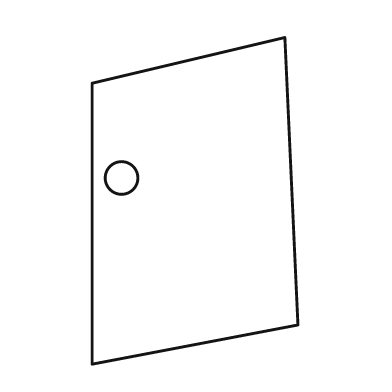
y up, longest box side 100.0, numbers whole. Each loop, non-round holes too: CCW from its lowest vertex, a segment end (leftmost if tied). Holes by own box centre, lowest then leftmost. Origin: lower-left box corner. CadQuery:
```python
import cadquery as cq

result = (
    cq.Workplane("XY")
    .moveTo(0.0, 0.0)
    .lineTo(63.0, 12.0)
    .lineTo(59.0, 100.0)
    .lineTo(0.0, 86.0)
    .close()
    .moveTo(9.0, 57.0)
    .circle(5.0)
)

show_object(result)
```